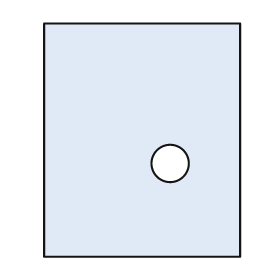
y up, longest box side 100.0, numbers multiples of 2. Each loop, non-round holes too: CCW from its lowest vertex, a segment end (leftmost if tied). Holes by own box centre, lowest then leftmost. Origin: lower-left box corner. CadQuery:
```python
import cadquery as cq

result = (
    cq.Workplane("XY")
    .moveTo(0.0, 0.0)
    .lineTo(84.0, 0.0)
    .lineTo(84.0, 100.0)
    .lineTo(0.0, 100.0)
    .close()
    .moveTo(54.0, 40.0)
    .circle(8.0)
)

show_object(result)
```